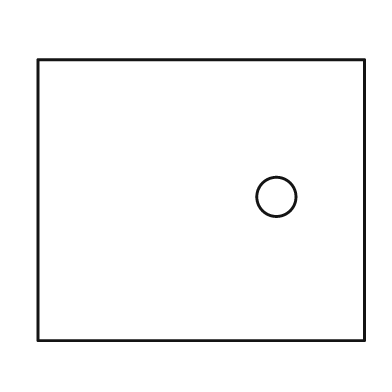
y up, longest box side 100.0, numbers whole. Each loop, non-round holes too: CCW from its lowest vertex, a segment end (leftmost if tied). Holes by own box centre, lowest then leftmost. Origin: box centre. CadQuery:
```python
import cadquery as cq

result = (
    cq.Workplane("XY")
    .moveTo(-50.0, -43.0)
    .lineTo(50.0, -43.0)
    .lineTo(50.0, 43.0)
    .lineTo(-50.0, 43.0)
    .close()
    .moveTo(23.0, 1.0)
    .circle(6.0)
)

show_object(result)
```